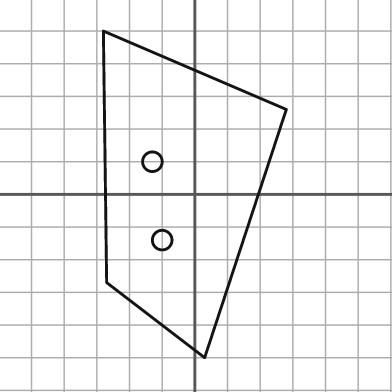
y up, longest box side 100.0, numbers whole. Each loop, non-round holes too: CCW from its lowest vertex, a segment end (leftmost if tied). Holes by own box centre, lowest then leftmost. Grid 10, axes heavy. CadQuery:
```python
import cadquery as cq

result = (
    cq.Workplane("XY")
    .moveTo(3.0, -50.0)
    .lineTo(28.0, 26.0)
    .lineTo(-28.0, 50.0)
    .lineTo(-27.0, -27.0)
    .close()
    .moveTo(-10.0, -14.0)
    .circle(3.0)
    .moveTo(-13.0, 10.0)
    .circle(3.0)
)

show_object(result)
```